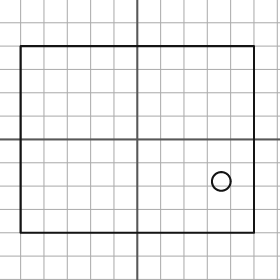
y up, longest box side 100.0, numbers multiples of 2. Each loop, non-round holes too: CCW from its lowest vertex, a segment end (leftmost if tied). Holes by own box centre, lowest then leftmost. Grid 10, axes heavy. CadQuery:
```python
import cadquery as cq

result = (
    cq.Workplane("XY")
    .moveTo(-50.0, -40.0)
    .lineTo(50.0, -40.0)
    .lineTo(50.0, 40.0)
    .lineTo(-50.0, 40.0)
    .close()
    .moveTo(36.0, -18.0)
    .circle(4.0)
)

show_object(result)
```